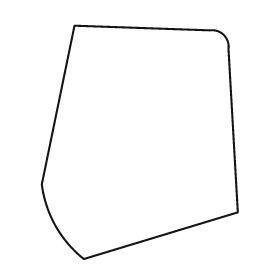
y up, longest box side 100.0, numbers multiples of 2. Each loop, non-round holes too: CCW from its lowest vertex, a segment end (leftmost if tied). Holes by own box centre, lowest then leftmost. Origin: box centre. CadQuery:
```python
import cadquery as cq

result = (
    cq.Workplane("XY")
    .moveTo(-24.0, -50.0)
    .lineTo(42.0, -30.0)
    .lineTo(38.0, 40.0)
    .threePointArc((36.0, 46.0), (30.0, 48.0))
    .lineTo(-28.0, 50.0)
    .lineTo(-42.0, -18.0)
    .threePointArc((-36.0, -36.0), (-24.0, -50.0))
    .close()
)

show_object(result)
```